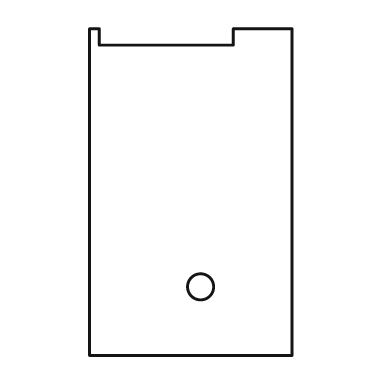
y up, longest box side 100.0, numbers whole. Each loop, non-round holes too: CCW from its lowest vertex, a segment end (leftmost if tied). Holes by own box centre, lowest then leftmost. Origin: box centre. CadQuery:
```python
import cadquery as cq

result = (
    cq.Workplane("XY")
    .moveTo(-31.0, -50.0)
    .lineTo(31.0, -50.0)
    .lineTo(31.0, 50.0)
    .lineTo(13.0, 50.0)
    .lineTo(13.0, 45.0)
    .lineTo(-28.0, 45.0)
    .lineTo(-28.0, 50.0)
    .lineTo(-31.0, 50.0)
    .close()
    .moveTo(3.0, -29.0)
    .circle(4.0)
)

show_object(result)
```